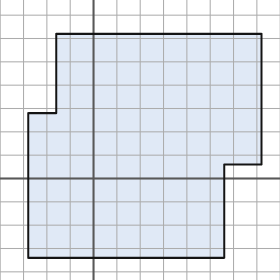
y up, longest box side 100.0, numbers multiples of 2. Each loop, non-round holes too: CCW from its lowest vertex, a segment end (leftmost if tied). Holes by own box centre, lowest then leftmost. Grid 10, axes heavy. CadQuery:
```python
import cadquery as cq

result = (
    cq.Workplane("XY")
    .moveTo(-28.0, -34.0)
    .lineTo(56.0, -34.0)
    .lineTo(56.0, 6.0)
    .lineTo(72.0, 6.0)
    .lineTo(72.0, 62.0)
    .lineTo(-16.0, 62.0)
    .lineTo(-16.0, 28.0)
    .lineTo(-28.0, 28.0)
    .close()
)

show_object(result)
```